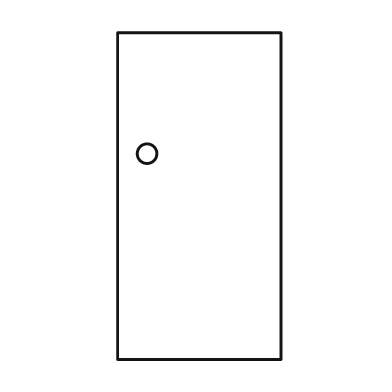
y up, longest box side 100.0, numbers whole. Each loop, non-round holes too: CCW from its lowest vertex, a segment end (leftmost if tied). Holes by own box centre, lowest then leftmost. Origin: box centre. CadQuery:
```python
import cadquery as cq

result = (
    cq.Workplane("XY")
    .moveTo(-25.0, -50.0)
    .lineTo(25.0, -50.0)
    .lineTo(25.0, 50.0)
    .lineTo(-25.0, 50.0)
    .close()
    .moveTo(-16.0, 13.0)
    .circle(3.0)
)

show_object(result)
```